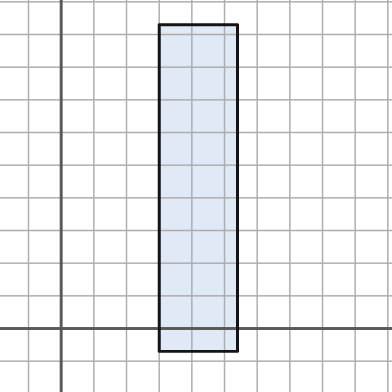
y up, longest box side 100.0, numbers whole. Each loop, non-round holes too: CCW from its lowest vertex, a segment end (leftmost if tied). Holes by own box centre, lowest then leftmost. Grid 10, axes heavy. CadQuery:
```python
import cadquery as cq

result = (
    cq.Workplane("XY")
    .moveTo(30.0, -7.0)
    .lineTo(54.0, -7.0)
    .lineTo(54.0, 93.0)
    .lineTo(30.0, 93.0)
    .close()
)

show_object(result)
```